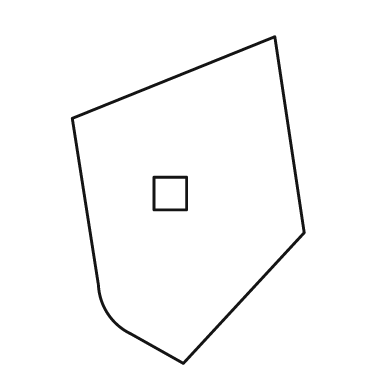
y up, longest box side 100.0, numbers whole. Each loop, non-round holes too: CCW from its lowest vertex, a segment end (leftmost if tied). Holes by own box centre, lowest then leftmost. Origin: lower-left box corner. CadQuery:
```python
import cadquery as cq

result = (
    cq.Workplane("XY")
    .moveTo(34.0, 0.0)
    .lineTo(71.0, 40.0)
    .lineTo(62.0, 100.0)
    .lineTo(0.0, 75.0)
    .lineTo(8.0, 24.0)
    .threePointArc((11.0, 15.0), (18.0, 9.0))
    .close()
    .moveTo(25.0, 47.0)
    .lineTo(35.0, 47.0)
    .lineTo(35.0, 57.0)
    .lineTo(25.0, 57.0)
    .close()
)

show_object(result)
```